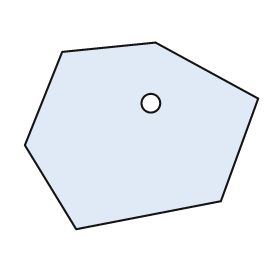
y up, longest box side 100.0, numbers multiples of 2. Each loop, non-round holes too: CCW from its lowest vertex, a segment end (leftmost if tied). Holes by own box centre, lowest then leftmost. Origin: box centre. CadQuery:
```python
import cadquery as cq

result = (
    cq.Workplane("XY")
    .moveTo(-28.0, -40.0)
    .lineTo(34.0, -28.0)
    .lineTo(50.0, 16.0)
    .lineTo(6.0, 40.0)
    .lineTo(-34.0, 36.0)
    .lineTo(-50.0, -4.0)
    .close()
    .moveTo(4.0, 14.0)
    .circle(4.0)
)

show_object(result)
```